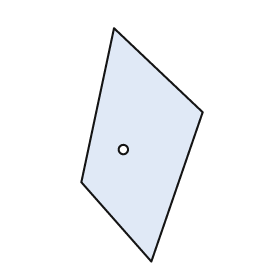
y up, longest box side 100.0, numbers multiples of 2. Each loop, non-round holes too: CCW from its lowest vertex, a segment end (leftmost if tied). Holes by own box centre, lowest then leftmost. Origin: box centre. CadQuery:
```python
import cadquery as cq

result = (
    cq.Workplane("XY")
    .moveTo(4.0, -50.0)
    .lineTo(26.0, 14.0)
    .lineTo(-12.0, 50.0)
    .lineTo(-26.0, -16.0)
    .close()
    .moveTo(-8.0, -2.0)
    .circle(2.0)
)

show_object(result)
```